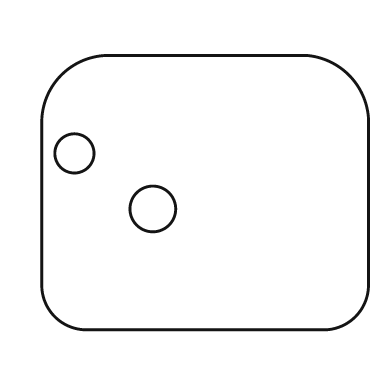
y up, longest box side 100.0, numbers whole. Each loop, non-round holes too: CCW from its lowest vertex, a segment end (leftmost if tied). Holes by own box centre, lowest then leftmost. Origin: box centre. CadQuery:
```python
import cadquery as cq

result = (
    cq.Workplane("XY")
    .moveTo(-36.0, -42.0)
    .lineTo(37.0, -42.0)
    .threePointArc((46.0, -38.0), (50.0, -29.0))
    .lineTo(50.0, 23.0)
    .threePointArc((44.0, 36.0), (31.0, 42.0))
    .lineTo(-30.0, 42.0)
    .threePointArc((-44.0, 36.0), (-50.0, 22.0))
    .lineTo(-50.0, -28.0)
    .threePointArc((-46.0, -38.0), (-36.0, -42.0))
    .close()
    .moveTo(-16.0, -5.0)
    .circle(7.0)
    .moveTo(-40.0, 12.0)
    .circle(6.0)
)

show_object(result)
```